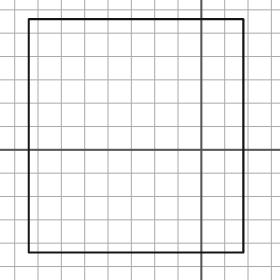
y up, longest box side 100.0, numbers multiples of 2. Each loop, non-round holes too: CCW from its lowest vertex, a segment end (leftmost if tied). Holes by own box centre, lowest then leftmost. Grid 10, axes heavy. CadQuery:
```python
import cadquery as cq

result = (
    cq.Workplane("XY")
    .moveTo(-74.0, -44.0)
    .lineTo(18.0, -44.0)
    .lineTo(18.0, 56.0)
    .lineTo(-74.0, 56.0)
    .close()
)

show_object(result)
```